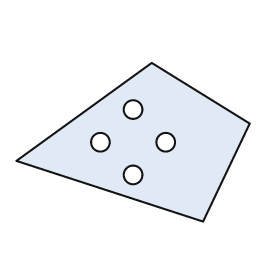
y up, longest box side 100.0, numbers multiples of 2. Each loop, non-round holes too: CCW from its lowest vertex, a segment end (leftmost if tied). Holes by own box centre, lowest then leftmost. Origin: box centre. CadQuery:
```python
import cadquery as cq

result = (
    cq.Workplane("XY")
    .moveTo(30.0, -34.0)
    .lineTo(50.0, 8.0)
    .lineTo(8.0, 34.0)
    .lineTo(-50.0, -8.0)
    .close()
    .moveTo(0.0, -14.0)
    .circle(4.0)
    .moveTo(-14.0, 0.0)
    .circle(4.0)
    .moveTo(14.0, 0.0)
    .circle(4.0)
    .moveTo(0.0, 14.0)
    .circle(4.0)
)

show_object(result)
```